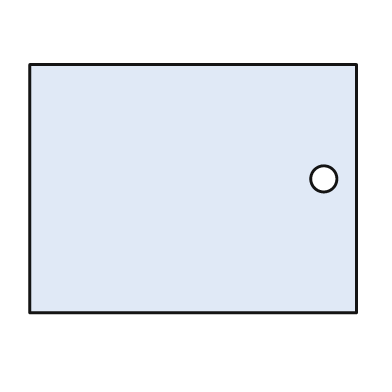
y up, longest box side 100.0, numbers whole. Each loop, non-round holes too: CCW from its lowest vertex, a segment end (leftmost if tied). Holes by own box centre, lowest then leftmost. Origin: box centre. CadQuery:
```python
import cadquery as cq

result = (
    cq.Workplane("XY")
    .moveTo(-50.0, -38.0)
    .lineTo(50.0, -38.0)
    .lineTo(50.0, 38.0)
    .lineTo(-50.0, 38.0)
    .close()
    .moveTo(40.0, 3.0)
    .circle(4.0)
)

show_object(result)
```